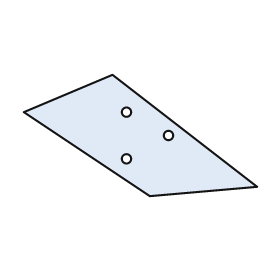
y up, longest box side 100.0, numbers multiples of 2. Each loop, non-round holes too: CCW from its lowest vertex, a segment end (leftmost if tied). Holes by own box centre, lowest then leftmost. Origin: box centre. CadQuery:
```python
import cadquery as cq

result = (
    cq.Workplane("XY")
    .moveTo(4.0, -26.0)
    .lineTo(50.0, -22.0)
    .lineTo(-12.0, 26.0)
    .lineTo(-50.0, 10.0)
    .close()
    .moveTo(-6.0, -10.0)
    .circle(2.0)
    .moveTo(12.0, 0.0)
    .circle(2.0)
    .moveTo(-6.0, 10.0)
    .circle(2.0)
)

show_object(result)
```